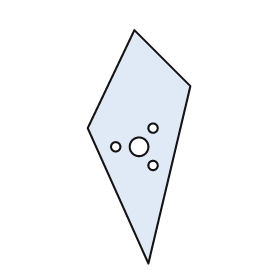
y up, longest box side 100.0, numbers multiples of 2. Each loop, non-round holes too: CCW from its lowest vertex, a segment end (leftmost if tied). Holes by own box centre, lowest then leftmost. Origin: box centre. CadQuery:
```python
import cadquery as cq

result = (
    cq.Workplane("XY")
    .moveTo(4.0, -50.0)
    .lineTo(22.0, 26.0)
    .lineTo(-2.0, 50.0)
    .lineTo(-22.0, 8.0)
    .close()
    .moveTo(6.0, -8.0)
    .circle(2.0)
    .moveTo(-10.0, 0.0)
    .circle(2.0)
    .moveTo(0.0, 0.0)
    .circle(4.0)
    .moveTo(6.0, 8.0)
    .circle(2.0)
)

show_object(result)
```